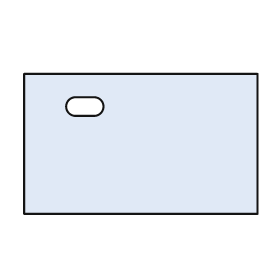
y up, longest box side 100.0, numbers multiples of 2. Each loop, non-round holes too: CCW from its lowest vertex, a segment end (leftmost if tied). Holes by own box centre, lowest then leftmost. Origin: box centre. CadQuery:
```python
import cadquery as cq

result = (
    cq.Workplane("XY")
    .moveTo(-50.0, -30.0)
    .lineTo(50.0, -30.0)
    .lineTo(50.0, 30.0)
    .lineTo(-50.0, 30.0)
    .close()
    .moveTo(-28.0, 12.0)
    .lineTo(-20.0, 12.0)
    .threePointArc((-16.0, 16.0), (-20.0, 20.0))
    .lineTo(-28.0, 20.0)
    .threePointArc((-32.0, 16.0), (-28.0, 12.0))
    .close()
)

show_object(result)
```